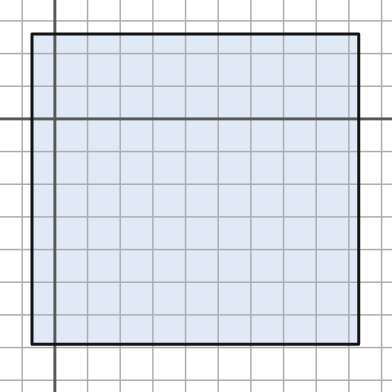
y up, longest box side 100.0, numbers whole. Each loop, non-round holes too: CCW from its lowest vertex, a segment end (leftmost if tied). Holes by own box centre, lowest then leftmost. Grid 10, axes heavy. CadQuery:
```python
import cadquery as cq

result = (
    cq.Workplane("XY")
    .moveTo(-7.0, -69.0)
    .lineTo(93.0, -69.0)
    .lineTo(93.0, 26.0)
    .lineTo(-7.0, 26.0)
    .close()
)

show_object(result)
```